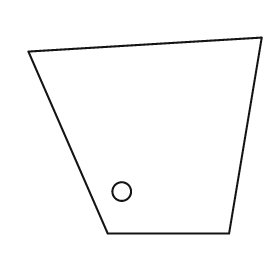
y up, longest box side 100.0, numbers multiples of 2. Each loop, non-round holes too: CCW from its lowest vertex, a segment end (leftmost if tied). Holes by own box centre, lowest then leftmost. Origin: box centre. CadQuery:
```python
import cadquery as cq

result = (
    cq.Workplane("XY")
    .moveTo(-16.0, -42.0)
    .lineTo(36.0, -42.0)
    .lineTo(50.0, 42.0)
    .lineTo(-50.0, 36.0)
    .close()
    .moveTo(-10.0, -24.0)
    .circle(4.0)
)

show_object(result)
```